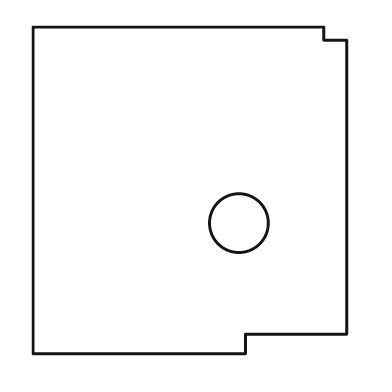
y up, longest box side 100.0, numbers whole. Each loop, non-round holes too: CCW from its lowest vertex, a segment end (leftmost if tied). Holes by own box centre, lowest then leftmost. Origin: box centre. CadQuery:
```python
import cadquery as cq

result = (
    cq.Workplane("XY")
    .moveTo(-48.0, -50.0)
    .lineTo(17.0, -50.0)
    .lineTo(17.0, -44.0)
    .lineTo(48.0, -44.0)
    .lineTo(48.0, 46.0)
    .lineTo(41.0, 46.0)
    .lineTo(41.0, 50.0)
    .lineTo(-48.0, 50.0)
    .close()
    .moveTo(15.0, -10.0)
    .circle(9.0)
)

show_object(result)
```